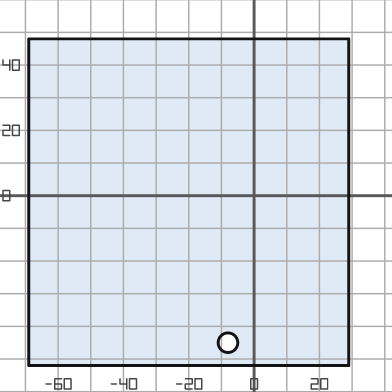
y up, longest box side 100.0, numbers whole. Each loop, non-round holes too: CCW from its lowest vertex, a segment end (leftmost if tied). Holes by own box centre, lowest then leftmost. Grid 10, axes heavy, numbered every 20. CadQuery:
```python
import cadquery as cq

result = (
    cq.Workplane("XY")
    .moveTo(-69.0, -52.0)
    .lineTo(29.0, -52.0)
    .lineTo(29.0, 48.0)
    .lineTo(-69.0, 48.0)
    .close()
    .moveTo(-8.0, -45.0)
    .circle(3.0)
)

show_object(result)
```